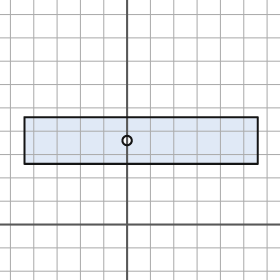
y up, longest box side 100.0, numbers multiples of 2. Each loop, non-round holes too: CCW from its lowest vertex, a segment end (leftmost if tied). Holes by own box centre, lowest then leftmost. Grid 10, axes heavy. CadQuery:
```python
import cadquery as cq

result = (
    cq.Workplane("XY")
    .moveTo(-44.0, 26.0)
    .lineTo(56.0, 26.0)
    .lineTo(56.0, 46.0)
    .lineTo(-44.0, 46.0)
    .close()
    .moveTo(0.0, 36.0)
    .circle(2.0)
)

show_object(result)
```